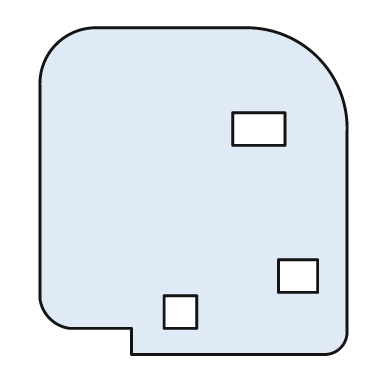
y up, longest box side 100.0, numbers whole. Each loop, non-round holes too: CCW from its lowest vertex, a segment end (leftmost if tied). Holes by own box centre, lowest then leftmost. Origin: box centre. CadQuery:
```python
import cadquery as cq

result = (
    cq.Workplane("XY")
    .moveTo(-19.0, -50.0)
    .lineTo(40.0, -50.0)
    .threePointArc((45.0, -48.0), (47.0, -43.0))
    .lineTo(47.0, 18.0)
    .threePointArc((38.0, 41.0), (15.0, 50.0))
    .lineTo(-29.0, 50.0)
    .threePointArc((-42.0, 45.0), (-47.0, 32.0))
    .lineTo(-47.0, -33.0)
    .threePointArc((-44.0, -39.0), (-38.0, -42.0))
    .lineTo(-19.0, -42.0)
    .close()
    .moveTo(-9.0, -42.0)
    .lineTo(1.0, -42.0)
    .lineTo(1.0, -32.0)
    .lineTo(-9.0, -32.0)
    .close()
    .moveTo(26.0, -31.0)
    .lineTo(38.0, -31.0)
    .lineTo(38.0, -21.0)
    .lineTo(26.0, -21.0)
    .close()
    .moveTo(12.0, 14.0)
    .lineTo(28.0, 14.0)
    .lineTo(28.0, 24.0)
    .lineTo(12.0, 24.0)
    .close()
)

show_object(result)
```